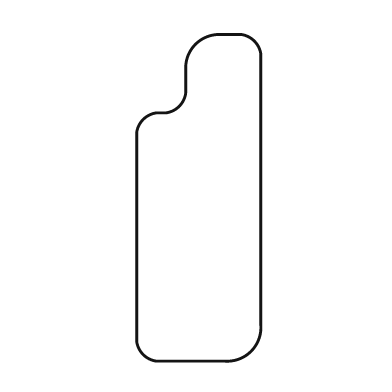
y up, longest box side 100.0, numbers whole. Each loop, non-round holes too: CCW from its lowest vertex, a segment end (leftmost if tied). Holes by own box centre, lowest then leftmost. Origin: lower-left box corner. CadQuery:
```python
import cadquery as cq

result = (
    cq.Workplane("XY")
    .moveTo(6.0, 0.0)
    .lineTo(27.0, 0.0)
    .threePointArc((35.0, 3.0), (38.0, 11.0))
    .lineTo(38.0, 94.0)
    .threePointArc((36.0, 98.0), (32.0, 100.0))
    .lineTo(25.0, 100.0)
    .threePointArc((18.0, 97.0), (15.0, 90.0))
    .lineTo(15.0, 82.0)
    .threePointArc((13.0, 78.0), (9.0, 76.0))
    .lineTo(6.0, 76.0)
    .threePointArc((2.0, 74.0), (0.0, 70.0))
    .lineTo(0.0, 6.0)
    .threePointArc((2.0, 2.0), (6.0, 0.0))
    .close()
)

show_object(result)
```